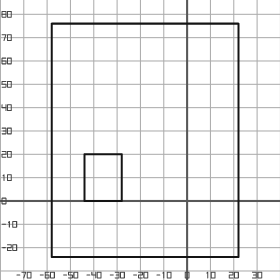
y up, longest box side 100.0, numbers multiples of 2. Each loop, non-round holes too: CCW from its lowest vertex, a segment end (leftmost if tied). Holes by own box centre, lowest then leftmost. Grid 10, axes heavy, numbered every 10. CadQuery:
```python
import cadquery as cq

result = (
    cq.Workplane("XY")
    .moveTo(-58.0, -24.0)
    .lineTo(22.0, -24.0)
    .lineTo(22.0, 76.0)
    .lineTo(-58.0, 76.0)
    .close()
    .moveTo(-44.0, 0.0)
    .lineTo(-28.0, 0.0)
    .lineTo(-28.0, 20.0)
    .lineTo(-44.0, 20.0)
    .close()
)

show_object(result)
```